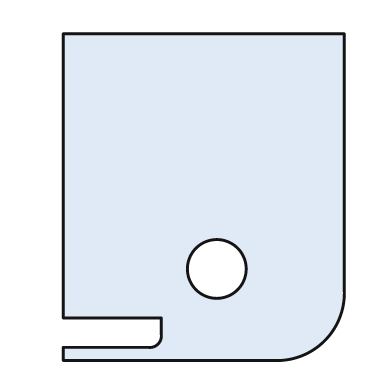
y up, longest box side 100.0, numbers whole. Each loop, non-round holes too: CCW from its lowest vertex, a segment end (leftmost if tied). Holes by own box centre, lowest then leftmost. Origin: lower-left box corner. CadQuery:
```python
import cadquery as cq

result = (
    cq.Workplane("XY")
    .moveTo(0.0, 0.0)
    .lineTo(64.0, 0.0)
    .threePointArc((80.0, 6.0), (86.0, 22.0))
    .lineTo(86.0, 100.0)
    .lineTo(0.0, 100.0)
    .lineTo(0.0, 13.0)
    .lineTo(30.0, 13.0)
    .lineTo(30.0, 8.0)
    .threePointArc((29.0, 5.0), (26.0, 4.0))
    .lineTo(0.0, 4.0)
    .close()
    .moveTo(47.0, 28.0)
    .circle(9.0)
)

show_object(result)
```